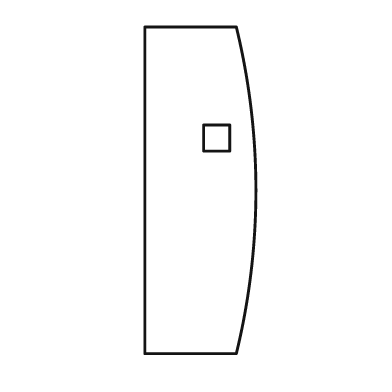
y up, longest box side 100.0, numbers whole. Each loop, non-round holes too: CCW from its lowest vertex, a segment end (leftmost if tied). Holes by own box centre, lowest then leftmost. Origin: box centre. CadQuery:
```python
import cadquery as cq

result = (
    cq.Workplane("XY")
    .moveTo(-17.0, -50.0)
    .lineTo(11.0, -50.0)
    .threePointArc((17.0, 0.0), (11.0, 50.0))
    .lineTo(-17.0, 50.0)
    .close()
    .moveTo(1.0, 12.0)
    .lineTo(9.0, 12.0)
    .lineTo(9.0, 20.0)
    .lineTo(1.0, 20.0)
    .close()
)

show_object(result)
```